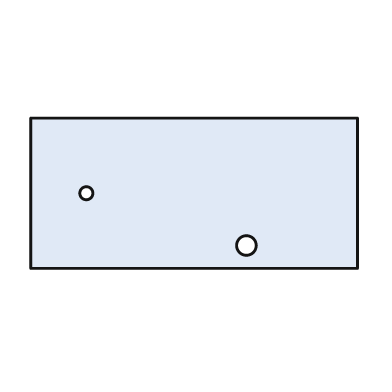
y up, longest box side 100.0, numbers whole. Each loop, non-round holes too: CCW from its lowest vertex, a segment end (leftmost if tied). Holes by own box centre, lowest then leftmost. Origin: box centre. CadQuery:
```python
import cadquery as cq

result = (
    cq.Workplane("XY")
    .moveTo(-50.0, -23.0)
    .lineTo(50.0, -23.0)
    .lineTo(50.0, 23.0)
    .lineTo(-50.0, 23.0)
    .close()
    .moveTo(16.0, -16.0)
    .circle(3.0)
    .moveTo(-33.0, 0.0)
    .circle(2.0)
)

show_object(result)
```